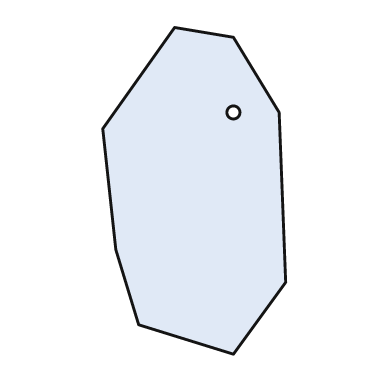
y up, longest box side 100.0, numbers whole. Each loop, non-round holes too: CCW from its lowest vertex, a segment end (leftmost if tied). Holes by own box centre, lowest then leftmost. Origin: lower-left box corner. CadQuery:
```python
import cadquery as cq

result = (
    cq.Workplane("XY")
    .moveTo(40.0, 0.0)
    .lineTo(56.0, 22.0)
    .lineTo(54.0, 74.0)
    .lineTo(40.0, 97.0)
    .lineTo(22.0, 100.0)
    .lineTo(0.0, 69.0)
    .lineTo(4.0, 32.0)
    .lineTo(11.0, 9.0)
    .close()
    .moveTo(40.0, 74.0)
    .circle(2.0)
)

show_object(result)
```